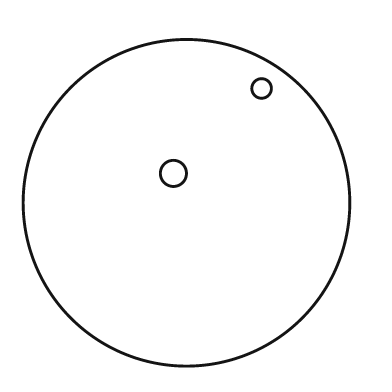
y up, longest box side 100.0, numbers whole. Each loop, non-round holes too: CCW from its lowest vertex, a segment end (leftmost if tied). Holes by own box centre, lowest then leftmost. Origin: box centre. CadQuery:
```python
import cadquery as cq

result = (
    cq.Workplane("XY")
    .moveTo(0.0, 0.0)
    .circle(50.0)
    .moveTo(-4.0, 9.0)
    .circle(4.0)
    .moveTo(23.0, 35.0)
    .circle(3.0)
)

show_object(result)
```